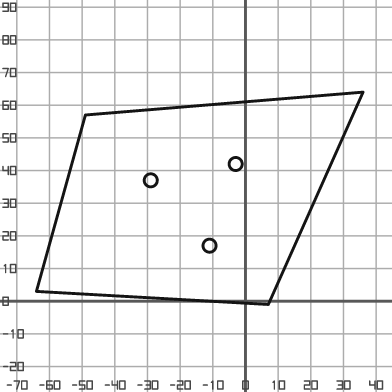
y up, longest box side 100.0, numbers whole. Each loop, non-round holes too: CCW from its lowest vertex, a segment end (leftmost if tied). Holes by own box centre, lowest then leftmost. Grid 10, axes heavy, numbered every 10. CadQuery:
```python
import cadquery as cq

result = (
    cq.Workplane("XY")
    .moveTo(7.0, -1.0)
    .lineTo(36.0, 64.0)
    .lineTo(-49.0, 57.0)
    .lineTo(-64.0, 3.0)
    .close()
    .moveTo(-11.0, 17.0)
    .circle(2.0)
    .moveTo(-29.0, 37.0)
    .circle(2.0)
    .moveTo(-3.0, 42.0)
    .circle(2.0)
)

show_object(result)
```